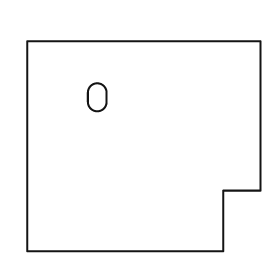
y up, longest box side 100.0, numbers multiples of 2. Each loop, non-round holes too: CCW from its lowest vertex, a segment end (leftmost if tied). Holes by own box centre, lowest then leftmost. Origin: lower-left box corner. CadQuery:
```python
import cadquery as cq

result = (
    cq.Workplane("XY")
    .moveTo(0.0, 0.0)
    .lineTo(84.0, 0.0)
    .lineTo(84.0, 26.0)
    .lineTo(100.0, 26.0)
    .lineTo(100.0, 90.0)
    .lineTo(0.0, 90.0)
    .close()
    .moveTo(26.0, 64.0)
    .threePointArc((30.0, 60.0), (34.0, 64.0))
    .lineTo(34.0, 68.0)
    .threePointArc((30.0, 72.0), (26.0, 68.0))
    .close()
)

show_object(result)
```